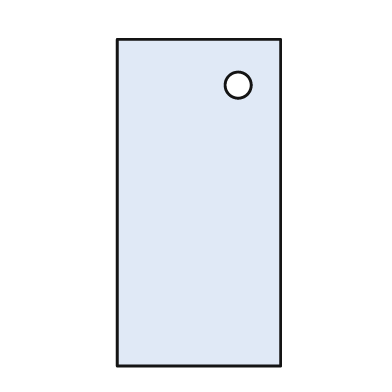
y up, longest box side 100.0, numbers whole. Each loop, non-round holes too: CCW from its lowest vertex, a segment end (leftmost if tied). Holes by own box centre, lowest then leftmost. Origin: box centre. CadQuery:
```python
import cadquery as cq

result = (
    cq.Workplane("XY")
    .moveTo(-25.0, -50.0)
    .lineTo(25.0, -50.0)
    .lineTo(25.0, 50.0)
    .lineTo(-25.0, 50.0)
    .close()
    .moveTo(12.0, 36.0)
    .circle(4.0)
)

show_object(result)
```